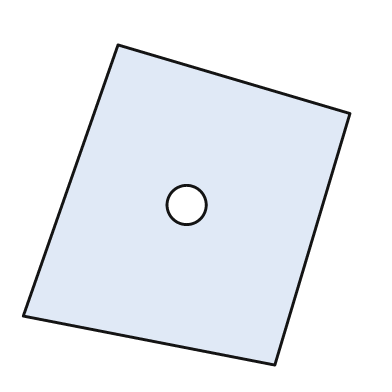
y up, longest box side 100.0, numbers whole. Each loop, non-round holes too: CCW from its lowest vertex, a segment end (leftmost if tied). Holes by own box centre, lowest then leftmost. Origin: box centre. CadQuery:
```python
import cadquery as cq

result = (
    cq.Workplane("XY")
    .moveTo(27.0, -49.0)
    .lineTo(50.0, 28.0)
    .lineTo(-21.0, 49.0)
    .lineTo(-50.0, -34.0)
    .close()
    .moveTo(0.0, 0.0)
    .circle(6.0)
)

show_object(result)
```